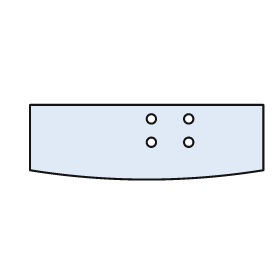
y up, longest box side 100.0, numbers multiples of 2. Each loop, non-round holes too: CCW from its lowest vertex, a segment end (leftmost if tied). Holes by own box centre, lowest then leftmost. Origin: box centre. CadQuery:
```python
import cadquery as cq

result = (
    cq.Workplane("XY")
    .moveTo(-50.0, -12.0)
    .threePointArc((0.0, -16.0), (50.0, -12.0))
    .lineTo(50.0, 16.0)
    .lineTo(-50.0, 16.0)
    .close()
    .moveTo(2.0, 0.0)
    .circle(2.0)
    .moveTo(18.0, 0.0)
    .circle(2.0)
    .moveTo(2.0, 10.0)
    .circle(2.0)
    .moveTo(18.0, 10.0)
    .circle(2.0)
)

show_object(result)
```